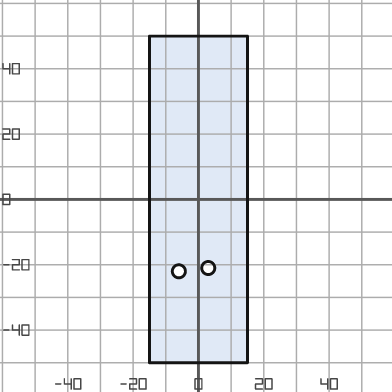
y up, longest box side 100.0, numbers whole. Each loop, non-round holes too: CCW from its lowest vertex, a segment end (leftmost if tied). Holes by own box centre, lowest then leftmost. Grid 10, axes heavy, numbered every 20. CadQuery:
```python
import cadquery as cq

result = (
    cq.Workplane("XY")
    .moveTo(-15.0, -50.0)
    .lineTo(15.0, -50.0)
    .lineTo(15.0, 50.0)
    .lineTo(-15.0, 50.0)
    .close()
    .moveTo(-6.0, -22.0)
    .circle(2.0)
    .moveTo(3.0, -21.0)
    .circle(2.0)
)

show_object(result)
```